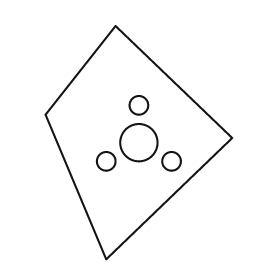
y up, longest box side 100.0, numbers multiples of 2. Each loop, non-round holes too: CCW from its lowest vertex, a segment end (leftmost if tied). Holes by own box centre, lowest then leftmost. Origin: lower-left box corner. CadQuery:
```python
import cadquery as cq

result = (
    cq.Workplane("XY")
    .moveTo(26.0, 0.0)
    .lineTo(80.0, 52.0)
    .lineTo(30.0, 100.0)
    .lineTo(0.0, 62.0)
    .close()
    .moveTo(26.0, 42.0)
    .circle(4.0)
    .moveTo(54.0, 42.0)
    .circle(4.0)
    .moveTo(40.0, 50.0)
    .circle(8.0)
    .moveTo(40.0, 66.0)
    .circle(4.0)
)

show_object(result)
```